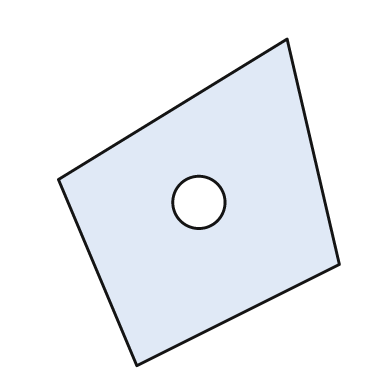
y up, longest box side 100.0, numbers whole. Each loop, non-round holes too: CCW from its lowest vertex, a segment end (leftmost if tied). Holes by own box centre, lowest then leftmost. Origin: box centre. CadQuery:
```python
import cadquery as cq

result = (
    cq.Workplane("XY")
    .moveTo(-19.0, -50.0)
    .lineTo(43.0, -19.0)
    .lineTo(27.0, 50.0)
    .lineTo(-43.0, 7.0)
    .close()
    .moveTo(0.0, 0.0)
    .circle(8.0)
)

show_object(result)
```